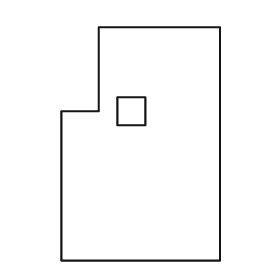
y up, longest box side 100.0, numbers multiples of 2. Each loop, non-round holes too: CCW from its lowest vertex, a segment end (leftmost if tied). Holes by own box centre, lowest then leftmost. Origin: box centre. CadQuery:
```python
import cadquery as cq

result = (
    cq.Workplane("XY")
    .moveTo(-34.0, -50.0)
    .lineTo(34.0, -50.0)
    .lineTo(34.0, 50.0)
    .lineTo(-18.0, 50.0)
    .lineTo(-18.0, 14.0)
    .lineTo(-34.0, 14.0)
    .close()
    .moveTo(-10.0, 8.0)
    .lineTo(2.0, 8.0)
    .lineTo(2.0, 20.0)
    .lineTo(-10.0, 20.0)
    .close()
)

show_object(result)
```